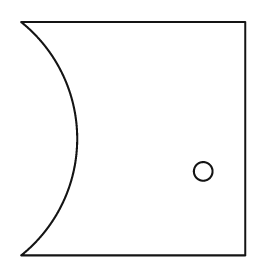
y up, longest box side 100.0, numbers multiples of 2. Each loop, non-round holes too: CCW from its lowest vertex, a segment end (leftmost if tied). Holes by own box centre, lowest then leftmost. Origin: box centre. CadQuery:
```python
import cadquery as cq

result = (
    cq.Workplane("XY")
    .moveTo(-48.0, -50.0)
    .lineTo(48.0, -50.0)
    .lineTo(48.0, 50.0)
    .lineTo(-48.0, 50.0)
    .threePointArc((-24.0, 0.0), (-48.0, -50.0))
    .close()
    .moveTo(30.0, -14.0)
    .circle(4.0)
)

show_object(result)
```